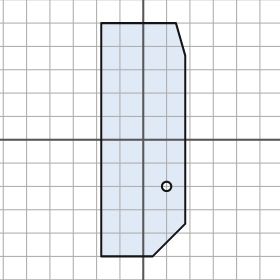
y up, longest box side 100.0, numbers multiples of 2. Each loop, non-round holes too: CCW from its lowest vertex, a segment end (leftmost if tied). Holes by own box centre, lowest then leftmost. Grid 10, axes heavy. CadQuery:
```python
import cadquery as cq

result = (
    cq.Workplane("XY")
    .moveTo(-18.0, -50.0)
    .lineTo(4.0, -50.0)
    .lineTo(18.0, -36.0)
    .lineTo(18.0, 36.0)
    .lineTo(14.0, 50.0)
    .lineTo(-18.0, 50.0)
    .close()
    .moveTo(10.0, -20.0)
    .circle(2.0)
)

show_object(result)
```